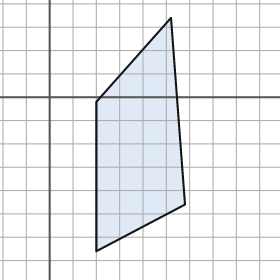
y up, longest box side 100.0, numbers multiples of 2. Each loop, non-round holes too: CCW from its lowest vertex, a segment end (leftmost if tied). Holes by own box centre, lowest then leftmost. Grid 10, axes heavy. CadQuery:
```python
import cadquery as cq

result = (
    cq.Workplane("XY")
    .moveTo(20.0, -66.0)
    .lineTo(58.0, -46.0)
    .lineTo(52.0, 34.0)
    .lineTo(20.0, -2.0)
    .close()
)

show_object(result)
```